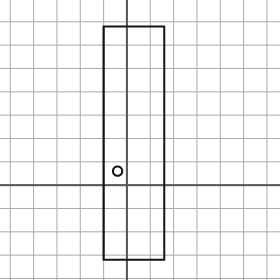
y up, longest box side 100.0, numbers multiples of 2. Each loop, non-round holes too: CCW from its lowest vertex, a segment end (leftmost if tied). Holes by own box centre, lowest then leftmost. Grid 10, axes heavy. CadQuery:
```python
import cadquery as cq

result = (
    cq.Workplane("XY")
    .moveTo(-10.0, -32.0)
    .lineTo(16.0, -32.0)
    .lineTo(16.0, 68.0)
    .lineTo(-10.0, 68.0)
    .close()
    .moveTo(-4.0, 6.0)
    .circle(2.0)
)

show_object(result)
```